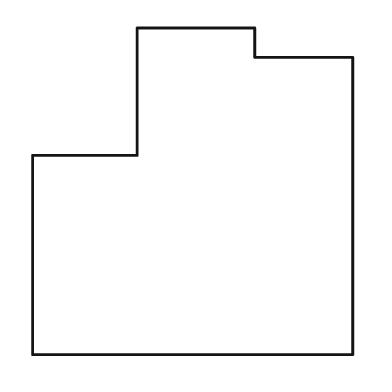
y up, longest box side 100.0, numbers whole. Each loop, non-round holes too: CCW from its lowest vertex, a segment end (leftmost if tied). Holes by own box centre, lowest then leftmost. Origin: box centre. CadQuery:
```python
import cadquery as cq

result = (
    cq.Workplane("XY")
    .moveTo(-49.0, -50.0)
    .lineTo(49.0, -50.0)
    .lineTo(49.0, 41.0)
    .lineTo(19.0, 41.0)
    .lineTo(19.0, 50.0)
    .lineTo(-17.0, 50.0)
    .lineTo(-17.0, 11.0)
    .lineTo(-49.0, 11.0)
    .close()
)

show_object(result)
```